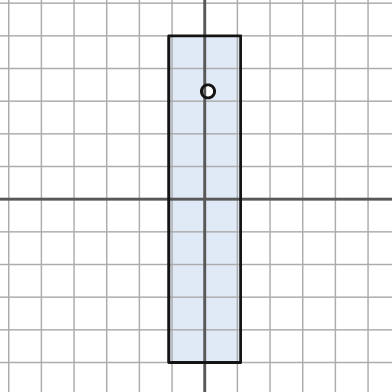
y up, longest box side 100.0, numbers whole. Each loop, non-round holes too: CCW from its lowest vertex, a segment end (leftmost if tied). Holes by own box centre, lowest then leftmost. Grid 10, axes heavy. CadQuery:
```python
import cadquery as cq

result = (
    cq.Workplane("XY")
    .moveTo(-11.0, -50.0)
    .lineTo(11.0, -50.0)
    .lineTo(11.0, 50.0)
    .lineTo(-11.0, 50.0)
    .close()
    .moveTo(1.0, 33.0)
    .circle(2.0)
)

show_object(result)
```